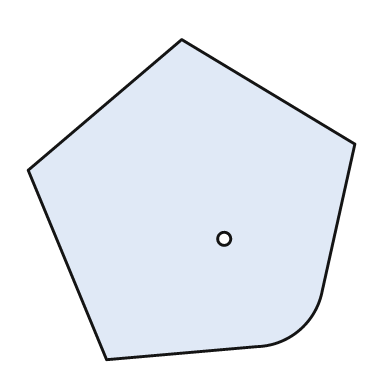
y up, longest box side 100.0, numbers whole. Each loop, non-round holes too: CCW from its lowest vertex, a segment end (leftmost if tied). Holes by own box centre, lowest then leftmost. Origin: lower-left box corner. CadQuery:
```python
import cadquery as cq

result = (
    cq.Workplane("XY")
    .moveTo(24.0, 0.0)
    .lineTo(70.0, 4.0)
    .threePointArc((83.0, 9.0), (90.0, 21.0))
    .lineTo(100.0, 66.0)
    .lineTo(47.0, 98.0)
    .lineTo(0.0, 58.0)
    .close()
    .moveTo(60.0, 37.0)
    .circle(2.0)
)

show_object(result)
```